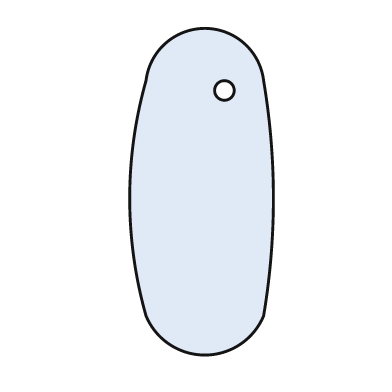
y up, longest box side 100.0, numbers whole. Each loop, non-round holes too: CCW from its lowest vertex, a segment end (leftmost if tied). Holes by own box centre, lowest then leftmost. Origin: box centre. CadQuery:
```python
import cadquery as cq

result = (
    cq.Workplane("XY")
    .moveTo(-17.0, -38.0)
    .threePointArc((1.0, -50.0), (19.0, -38.0))
    .threePointArc((22.0, -2.0), (19.0, 34.0))
    .threePointArc((1.0, 50.0), (-17.0, 34.0))
    .threePointArc((-22.0, -2.0), (-17.0, -38.0))
    .close()
    .moveTo(7.0, 31.0)
    .circle(3.0)
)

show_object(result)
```